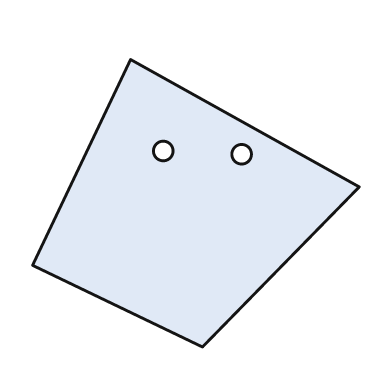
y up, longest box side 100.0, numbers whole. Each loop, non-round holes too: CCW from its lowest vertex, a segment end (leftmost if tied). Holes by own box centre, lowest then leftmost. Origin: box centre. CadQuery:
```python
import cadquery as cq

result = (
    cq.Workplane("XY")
    .moveTo(2.0, -44.0)
    .lineTo(50.0, 5.0)
    .lineTo(-20.0, 44.0)
    .lineTo(-50.0, -19.0)
    .close()
    .moveTo(14.0, 15.0)
    .circle(3.0)
    .moveTo(-10.0, 16.0)
    .circle(3.0)
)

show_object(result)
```